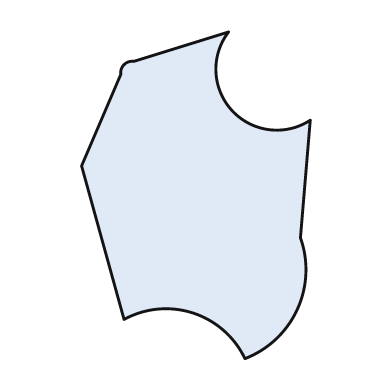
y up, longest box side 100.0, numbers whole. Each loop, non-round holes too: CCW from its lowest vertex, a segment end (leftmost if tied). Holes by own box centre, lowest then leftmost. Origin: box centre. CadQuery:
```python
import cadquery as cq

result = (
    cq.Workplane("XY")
    .moveTo(15.0, -50.0)
    .threePointArc((31.0, -35.0), (32.0, -13.0))
    .lineTo(35.0, 23.0)
    .threePointArc((11.0, 26.0), (10.0, 50.0))
    .lineTo(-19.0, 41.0)
    .threePointArc((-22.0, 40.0), (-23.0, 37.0))
    .lineTo(-35.0, 9.0)
    .lineTo(-22.0, -38.0)
    .threePointArc((-1.0, -36.0), (15.0, -50.0))
    .close()
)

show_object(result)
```